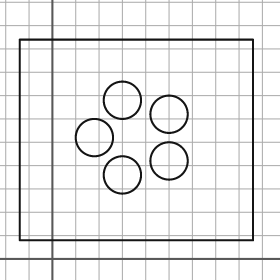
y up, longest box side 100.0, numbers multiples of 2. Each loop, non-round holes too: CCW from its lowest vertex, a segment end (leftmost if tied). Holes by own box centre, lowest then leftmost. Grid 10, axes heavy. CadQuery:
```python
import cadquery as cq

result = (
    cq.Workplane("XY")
    .moveTo(-14.0, 8.0)
    .lineTo(86.0, 8.0)
    .lineTo(86.0, 94.0)
    .lineTo(-14.0, 94.0)
    .close()
    .moveTo(30.0, 36.0)
    .circle(8.0)
    .moveTo(50.0, 42.0)
    .circle(8.0)
    .moveTo(18.0, 52.0)
    .circle(8.0)
    .moveTo(50.0, 62.0)
    .circle(8.0)
    .moveTo(30.0, 68.0)
    .circle(8.0)
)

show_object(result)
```